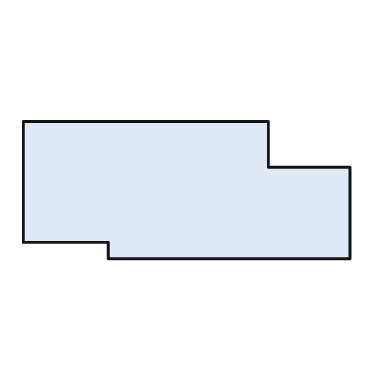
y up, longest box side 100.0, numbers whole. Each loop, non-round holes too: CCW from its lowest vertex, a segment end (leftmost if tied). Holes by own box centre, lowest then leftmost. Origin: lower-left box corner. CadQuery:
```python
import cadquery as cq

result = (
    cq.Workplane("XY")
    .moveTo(26.0, 0.0)
    .lineTo(100.0, 0.0)
    .lineTo(100.0, 28.0)
    .lineTo(75.0, 28.0)
    .lineTo(75.0, 42.0)
    .lineTo(0.0, 42.0)
    .lineTo(0.0, 5.0)
    .lineTo(26.0, 5.0)
    .close()
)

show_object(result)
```